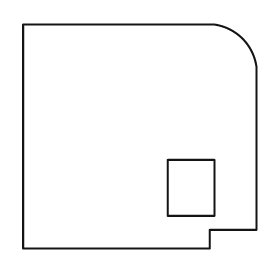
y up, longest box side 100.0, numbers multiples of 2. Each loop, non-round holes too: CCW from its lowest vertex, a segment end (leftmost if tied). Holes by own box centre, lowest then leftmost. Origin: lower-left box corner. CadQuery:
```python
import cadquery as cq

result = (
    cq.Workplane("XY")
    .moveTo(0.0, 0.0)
    .lineTo(80.0, 0.0)
    .lineTo(80.0, 8.0)
    .lineTo(100.0, 8.0)
    .lineTo(100.0, 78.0)
    .threePointArc((94.0, 90.0), (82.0, 96.0))
    .lineTo(0.0, 96.0)
    .close()
    .moveTo(62.0, 14.0)
    .lineTo(82.0, 14.0)
    .lineTo(82.0, 38.0)
    .lineTo(62.0, 38.0)
    .close()
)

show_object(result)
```